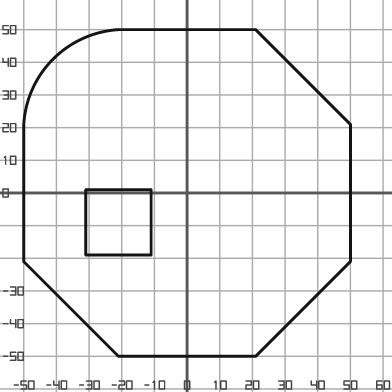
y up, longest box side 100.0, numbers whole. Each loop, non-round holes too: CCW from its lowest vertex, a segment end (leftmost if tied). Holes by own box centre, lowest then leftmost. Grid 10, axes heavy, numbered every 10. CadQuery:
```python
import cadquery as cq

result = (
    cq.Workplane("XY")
    .moveTo(-21.0, -50.0)
    .lineTo(21.0, -50.0)
    .lineTo(50.0, -21.0)
    .lineTo(50.0, 21.0)
    .lineTo(21.0, 50.0)
    .lineTo(-21.0, 50.0)
    .threePointArc((-41.0, 41.0), (-50.0, 21.0))
    .lineTo(-50.0, -21.0)
    .close()
    .moveTo(-31.0, -19.0)
    .lineTo(-11.0, -19.0)
    .lineTo(-11.0, 1.0)
    .lineTo(-31.0, 1.0)
    .close()
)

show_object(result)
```